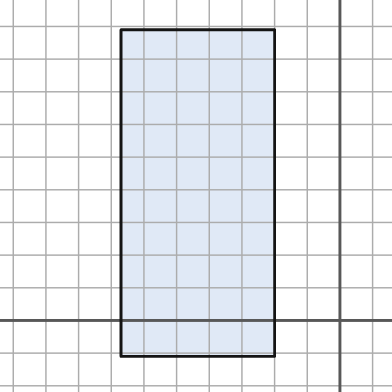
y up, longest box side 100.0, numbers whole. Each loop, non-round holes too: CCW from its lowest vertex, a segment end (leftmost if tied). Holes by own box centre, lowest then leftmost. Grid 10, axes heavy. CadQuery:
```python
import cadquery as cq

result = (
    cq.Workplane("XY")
    .moveTo(-67.0, -11.0)
    .lineTo(-20.0, -11.0)
    .lineTo(-20.0, 89.0)
    .lineTo(-67.0, 89.0)
    .close()
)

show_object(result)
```